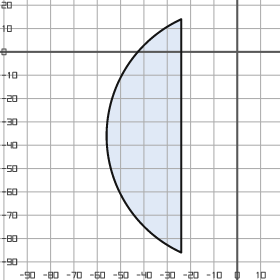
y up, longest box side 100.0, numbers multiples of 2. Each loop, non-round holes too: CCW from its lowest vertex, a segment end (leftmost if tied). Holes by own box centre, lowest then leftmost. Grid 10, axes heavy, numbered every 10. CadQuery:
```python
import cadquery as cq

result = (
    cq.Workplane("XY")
    .moveTo(-24.0, -86.0)
    .lineTo(-24.0, 14.0)
    .threePointArc((-56.0, -36.0), (-24.0, -86.0))
    .close()
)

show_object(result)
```